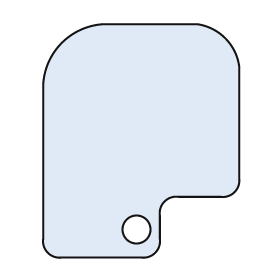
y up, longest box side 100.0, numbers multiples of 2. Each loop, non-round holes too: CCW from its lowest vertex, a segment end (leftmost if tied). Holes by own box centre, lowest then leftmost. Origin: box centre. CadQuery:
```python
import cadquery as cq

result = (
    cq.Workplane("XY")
    .moveTo(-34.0, -50.0)
    .lineTo(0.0, -50.0)
    .threePointArc((6.0, -48.0), (8.0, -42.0))
    .lineTo(8.0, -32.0)
    .threePointArc((10.0, -26.0), (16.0, -24.0))
    .lineTo(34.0, -24.0)
    .threePointArc((40.0, -22.0), (42.0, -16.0))
    .lineTo(42.0, 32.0)
    .threePointArc((36.0, 44.0), (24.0, 50.0))
    .lineTo(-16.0, 50.0)
    .threePointArc((-34.0, 42.0), (-42.0, 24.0))
    .lineTo(-42.0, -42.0)
    .threePointArc((-40.0, -48.0), (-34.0, -50.0))
    .close()
    .moveTo(-2.0, -38.0)
    .circle(6.0)
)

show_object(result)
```